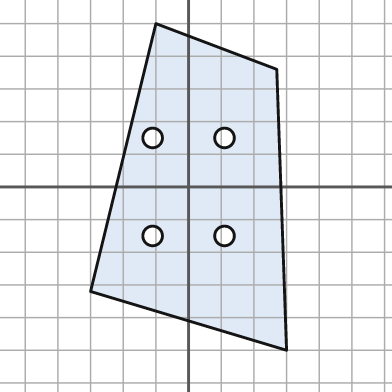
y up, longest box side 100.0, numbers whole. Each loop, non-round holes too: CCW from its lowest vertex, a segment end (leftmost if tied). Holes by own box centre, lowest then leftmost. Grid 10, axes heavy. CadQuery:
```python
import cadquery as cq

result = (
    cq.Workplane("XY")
    .moveTo(30.0, -50.0)
    .lineTo(27.0, 36.0)
    .lineTo(-10.0, 50.0)
    .lineTo(-30.0, -32.0)
    .close()
    .moveTo(-11.0, -15.0)
    .circle(3.0)
    .moveTo(11.0, -15.0)
    .circle(3.0)
    .moveTo(-11.0, 15.0)
    .circle(3.0)
    .moveTo(11.0, 15.0)
    .circle(3.0)
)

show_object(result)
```